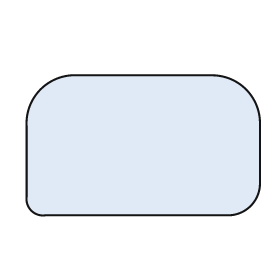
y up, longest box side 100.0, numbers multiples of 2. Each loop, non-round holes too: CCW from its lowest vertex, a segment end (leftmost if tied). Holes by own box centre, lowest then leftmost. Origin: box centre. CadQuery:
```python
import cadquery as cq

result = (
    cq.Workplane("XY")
    .moveTo(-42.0, -30.0)
    .lineTo(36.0, -30.0)
    .threePointArc((46.0, -26.0), (50.0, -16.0))
    .lineTo(50.0, 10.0)
    .threePointArc((44.0, 24.0), (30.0, 30.0))
    .lineTo(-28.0, 30.0)
    .threePointArc((-44.0, 24.0), (-50.0, 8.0))
    .lineTo(-50.0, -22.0)
    .threePointArc((-48.0, -28.0), (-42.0, -30.0))
    .close()
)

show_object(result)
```